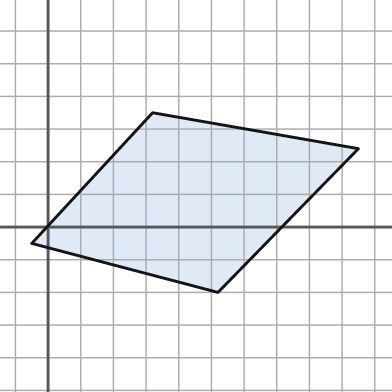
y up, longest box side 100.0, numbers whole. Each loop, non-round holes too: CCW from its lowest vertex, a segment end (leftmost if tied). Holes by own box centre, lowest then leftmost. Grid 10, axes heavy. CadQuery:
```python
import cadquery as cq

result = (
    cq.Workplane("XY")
    .moveTo(52.0, -20.0)
    .lineTo(95.0, 24.0)
    .lineTo(32.0, 35.0)
    .lineTo(-5.0, -5.0)
    .close()
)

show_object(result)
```